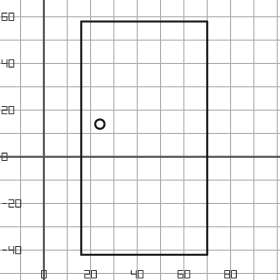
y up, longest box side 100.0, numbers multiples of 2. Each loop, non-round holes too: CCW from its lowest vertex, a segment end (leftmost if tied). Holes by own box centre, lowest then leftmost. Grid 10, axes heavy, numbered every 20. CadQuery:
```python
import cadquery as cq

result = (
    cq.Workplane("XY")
    .moveTo(16.0, -42.0)
    .lineTo(70.0, -42.0)
    .lineTo(70.0, 58.0)
    .lineTo(16.0, 58.0)
    .close()
    .moveTo(24.0, 14.0)
    .circle(2.0)
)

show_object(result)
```